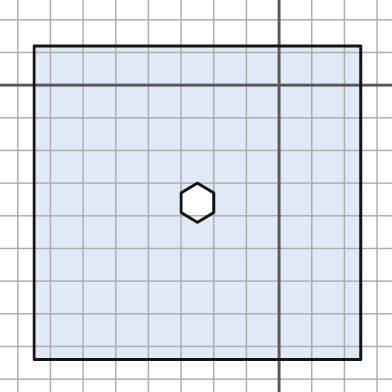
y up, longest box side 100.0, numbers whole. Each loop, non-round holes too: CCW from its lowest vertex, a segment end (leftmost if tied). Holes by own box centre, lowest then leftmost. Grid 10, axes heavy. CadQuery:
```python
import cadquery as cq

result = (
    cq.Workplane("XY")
    .moveTo(-75.0, -84.0)
    .lineTo(25.0, -84.0)
    .lineTo(25.0, 12.0)
    .lineTo(-75.0, 12.0)
    .close()
    .moveTo(-25.0, -42.0)
    .lineTo(-20.0, -39.0)
    .lineTo(-20.0, -33.0)
    .lineTo(-25.0, -30.0)
    .lineTo(-30.0, -33.0)
    .lineTo(-30.0, -39.0)
    .close()
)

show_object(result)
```